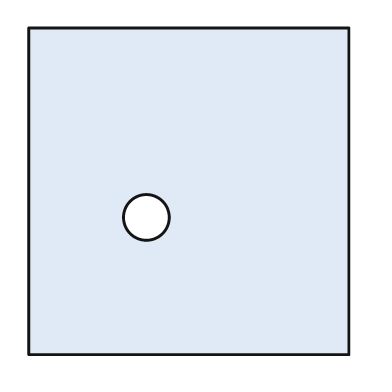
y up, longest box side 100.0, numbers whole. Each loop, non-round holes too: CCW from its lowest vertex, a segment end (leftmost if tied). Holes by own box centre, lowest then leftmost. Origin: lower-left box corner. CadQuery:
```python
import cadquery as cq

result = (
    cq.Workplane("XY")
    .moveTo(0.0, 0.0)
    .lineTo(98.0, 0.0)
    .lineTo(98.0, 100.0)
    .lineTo(0.0, 100.0)
    .close()
    .moveTo(36.0, 42.0)
    .circle(7.0)
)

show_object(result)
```